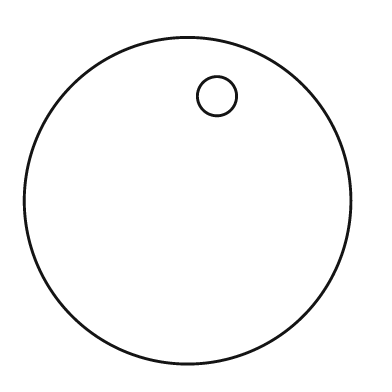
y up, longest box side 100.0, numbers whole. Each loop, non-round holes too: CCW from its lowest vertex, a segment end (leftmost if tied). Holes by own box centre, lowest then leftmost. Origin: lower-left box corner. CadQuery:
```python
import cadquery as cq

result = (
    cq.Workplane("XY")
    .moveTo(50.0, 50.0)
    .circle(50.0)
    .moveTo(59.0, 82.0)
    .circle(6.0)
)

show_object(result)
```